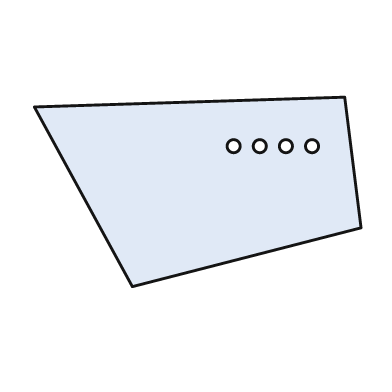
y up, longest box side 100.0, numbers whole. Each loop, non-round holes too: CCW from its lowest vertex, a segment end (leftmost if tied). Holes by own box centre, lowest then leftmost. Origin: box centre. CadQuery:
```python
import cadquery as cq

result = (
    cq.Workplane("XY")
    .moveTo(-20.0, -29.0)
    .lineTo(50.0, -11.0)
    .lineTo(45.0, 29.0)
    .lineTo(-50.0, 26.0)
    .close()
    .moveTo(11.0, 14.0)
    .circle(2.0)
    .moveTo(19.0, 14.0)
    .circle(2.0)
    .moveTo(27.0, 14.0)
    .circle(2.0)
    .moveTo(35.0, 14.0)
    .circle(2.0)
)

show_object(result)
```